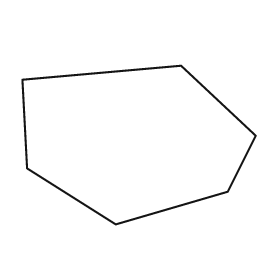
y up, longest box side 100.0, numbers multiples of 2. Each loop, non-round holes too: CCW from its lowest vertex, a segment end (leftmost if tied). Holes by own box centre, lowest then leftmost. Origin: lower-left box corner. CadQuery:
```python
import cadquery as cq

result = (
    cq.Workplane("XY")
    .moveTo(40.0, 0.0)
    .lineTo(88.0, 14.0)
    .lineTo(100.0, 38.0)
    .lineTo(68.0, 68.0)
    .lineTo(0.0, 62.0)
    .lineTo(2.0, 24.0)
    .close()
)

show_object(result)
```